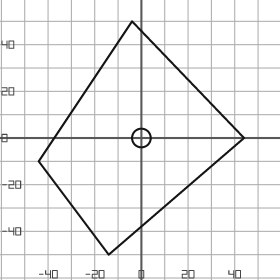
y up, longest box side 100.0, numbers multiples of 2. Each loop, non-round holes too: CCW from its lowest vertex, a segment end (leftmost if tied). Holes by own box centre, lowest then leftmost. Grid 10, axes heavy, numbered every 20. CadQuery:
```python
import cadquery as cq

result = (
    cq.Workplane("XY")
    .moveTo(-14.0, -50.0)
    .lineTo(44.0, 0.0)
    .lineTo(-4.0, 50.0)
    .lineTo(-44.0, -10.0)
    .close()
    .moveTo(0.0, 0.0)
    .circle(4.0)
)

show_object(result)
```